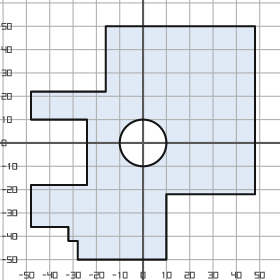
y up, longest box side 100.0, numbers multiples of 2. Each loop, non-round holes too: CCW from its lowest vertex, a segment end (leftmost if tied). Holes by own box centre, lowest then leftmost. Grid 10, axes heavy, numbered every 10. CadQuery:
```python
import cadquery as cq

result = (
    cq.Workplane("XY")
    .moveTo(-28.0, -50.0)
    .lineTo(10.0, -50.0)
    .lineTo(10.0, -22.0)
    .lineTo(48.0, -22.0)
    .lineTo(48.0, 50.0)
    .lineTo(-16.0, 50.0)
    .lineTo(-16.0, 22.0)
    .lineTo(-48.0, 22.0)
    .lineTo(-48.0, 10.0)
    .lineTo(-24.0, 10.0)
    .lineTo(-24.0, -18.0)
    .lineTo(-48.0, -18.0)
    .lineTo(-48.0, -36.0)
    .lineTo(-32.0, -36.0)
    .lineTo(-32.0, -42.0)
    .lineTo(-28.0, -42.0)
    .close()
    .moveTo(0.0, 0.0)
    .circle(10.0)
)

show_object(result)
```